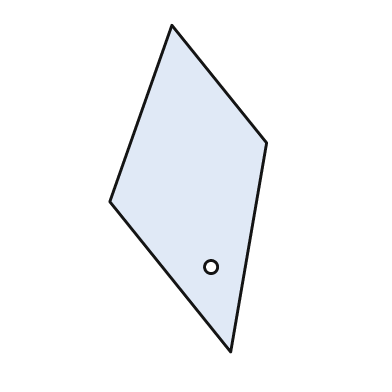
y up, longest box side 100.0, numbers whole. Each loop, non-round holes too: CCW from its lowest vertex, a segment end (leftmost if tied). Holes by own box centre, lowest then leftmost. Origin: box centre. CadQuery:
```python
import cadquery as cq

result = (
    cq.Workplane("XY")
    .moveTo(13.0, -50.0)
    .lineTo(24.0, 14.0)
    .lineTo(-5.0, 50.0)
    .lineTo(-24.0, -4.0)
    .close()
    .moveTo(7.0, -24.0)
    .circle(2.0)
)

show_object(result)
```